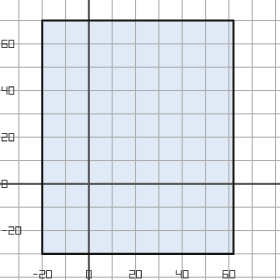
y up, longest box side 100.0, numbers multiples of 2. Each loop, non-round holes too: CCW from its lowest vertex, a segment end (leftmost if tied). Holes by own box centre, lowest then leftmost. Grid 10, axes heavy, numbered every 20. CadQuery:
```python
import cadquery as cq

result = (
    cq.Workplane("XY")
    .moveTo(-20.0, -30.0)
    .lineTo(62.0, -30.0)
    .lineTo(62.0, 70.0)
    .lineTo(-20.0, 70.0)
    .close()
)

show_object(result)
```